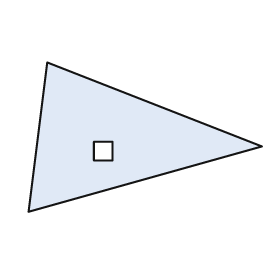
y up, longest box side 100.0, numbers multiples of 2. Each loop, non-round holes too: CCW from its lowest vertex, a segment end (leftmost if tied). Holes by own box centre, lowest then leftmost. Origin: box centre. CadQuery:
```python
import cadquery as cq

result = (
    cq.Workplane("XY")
    .moveTo(-50.0, -32.0)
    .lineTo(50.0, -4.0)
    .lineTo(-42.0, 32.0)
    .close()
    .moveTo(-22.0, -10.0)
    .lineTo(-14.0, -10.0)
    .lineTo(-14.0, -2.0)
    .lineTo(-22.0, -2.0)
    .close()
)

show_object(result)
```